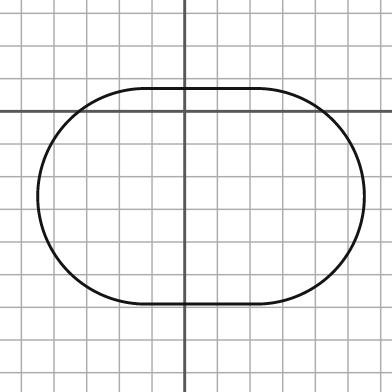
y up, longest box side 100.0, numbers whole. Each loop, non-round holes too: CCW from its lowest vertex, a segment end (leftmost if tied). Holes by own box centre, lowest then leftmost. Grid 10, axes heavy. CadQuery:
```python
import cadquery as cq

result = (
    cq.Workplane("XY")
    .moveTo(-12.0, -59.0)
    .lineTo(22.0, -59.0)
    .threePointArc((55.0, -26.0), (22.0, 7.0))
    .lineTo(-12.0, 7.0)
    .threePointArc((-45.0, -26.0), (-12.0, -59.0))
    .close()
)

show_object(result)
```